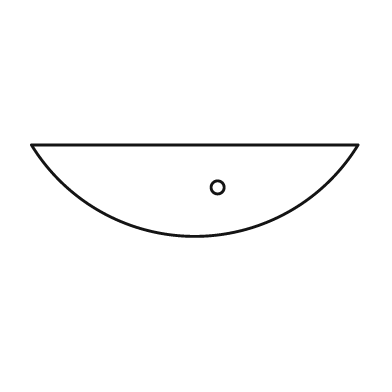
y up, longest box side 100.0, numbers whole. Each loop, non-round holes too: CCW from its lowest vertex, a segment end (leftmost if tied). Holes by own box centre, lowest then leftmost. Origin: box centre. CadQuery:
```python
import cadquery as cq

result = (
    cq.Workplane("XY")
    .moveTo(-50.0, 14.0)
    .threePointArc((0.0, -14.0), (50.0, 14.0))
    .close()
    .moveTo(7.0, 1.0)
    .circle(2.0)
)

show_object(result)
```